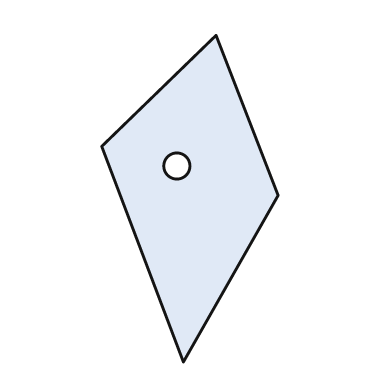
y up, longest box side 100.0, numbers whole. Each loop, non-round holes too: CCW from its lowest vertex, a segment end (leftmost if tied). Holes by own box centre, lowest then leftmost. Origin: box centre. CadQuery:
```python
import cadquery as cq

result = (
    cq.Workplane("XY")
    .moveTo(-2.0, -50.0)
    .lineTo(27.0, 1.0)
    .lineTo(8.0, 50.0)
    .lineTo(-27.0, 16.0)
    .close()
    .moveTo(-4.0, 10.0)
    .circle(4.0)
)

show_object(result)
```